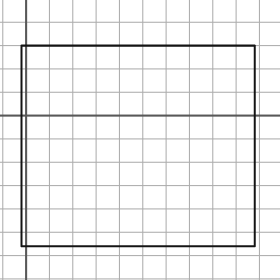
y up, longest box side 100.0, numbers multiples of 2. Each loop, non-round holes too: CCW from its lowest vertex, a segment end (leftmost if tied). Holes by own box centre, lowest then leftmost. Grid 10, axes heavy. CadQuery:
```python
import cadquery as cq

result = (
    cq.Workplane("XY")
    .moveTo(-2.0, -56.0)
    .lineTo(98.0, -56.0)
    .lineTo(98.0, 30.0)
    .lineTo(-2.0, 30.0)
    .close()
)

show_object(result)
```